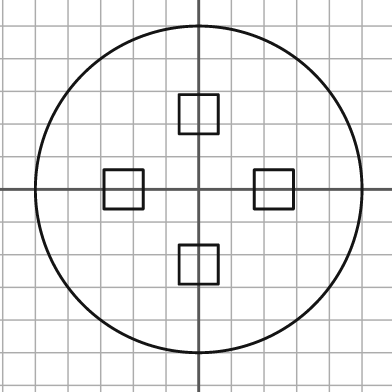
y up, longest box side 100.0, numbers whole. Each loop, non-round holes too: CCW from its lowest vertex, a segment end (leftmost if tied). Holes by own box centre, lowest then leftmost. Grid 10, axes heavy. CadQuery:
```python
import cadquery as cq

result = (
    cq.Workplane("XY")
    .moveTo(0.0, 0.0)
    .circle(50.0)
    .moveTo(-6.0, -29.0)
    .lineTo(6.0, -29.0)
    .lineTo(6.0, -17.0)
    .lineTo(-6.0, -17.0)
    .close()
    .moveTo(-29.0, -6.0)
    .lineTo(-17.0, -6.0)
    .lineTo(-17.0, 6.0)
    .lineTo(-29.0, 6.0)
    .close()
    .moveTo(17.0, -6.0)
    .lineTo(29.0, -6.0)
    .lineTo(29.0, 6.0)
    .lineTo(17.0, 6.0)
    .close()
    .moveTo(-6.0, 17.0)
    .lineTo(6.0, 17.0)
    .lineTo(6.0, 29.0)
    .lineTo(-6.0, 29.0)
    .close()
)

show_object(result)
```